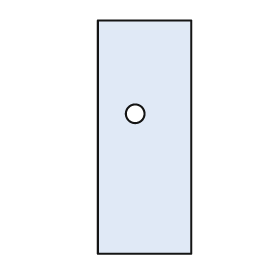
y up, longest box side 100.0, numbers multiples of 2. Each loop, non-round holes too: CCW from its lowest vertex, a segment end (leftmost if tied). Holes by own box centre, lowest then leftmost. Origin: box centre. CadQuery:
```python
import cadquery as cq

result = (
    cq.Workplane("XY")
    .moveTo(-20.0, -50.0)
    .lineTo(20.0, -50.0)
    .lineTo(20.0, 50.0)
    .lineTo(-20.0, 50.0)
    .close()
    .moveTo(-4.0, 10.0)
    .circle(4.0)
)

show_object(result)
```